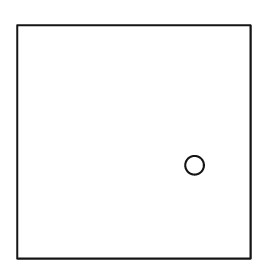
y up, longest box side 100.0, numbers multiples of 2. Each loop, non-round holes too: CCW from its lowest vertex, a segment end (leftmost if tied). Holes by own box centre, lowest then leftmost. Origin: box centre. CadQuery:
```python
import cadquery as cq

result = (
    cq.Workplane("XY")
    .moveTo(-50.0, -50.0)
    .lineTo(50.0, -50.0)
    .lineTo(50.0, 50.0)
    .lineTo(-50.0, 50.0)
    .close()
    .moveTo(26.0, -10.0)
    .circle(4.0)
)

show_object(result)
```